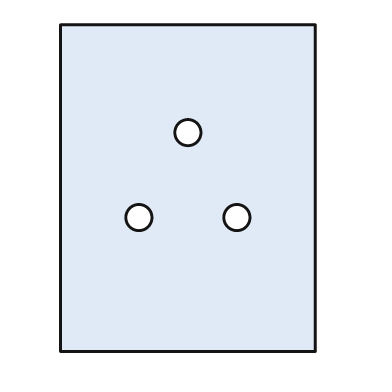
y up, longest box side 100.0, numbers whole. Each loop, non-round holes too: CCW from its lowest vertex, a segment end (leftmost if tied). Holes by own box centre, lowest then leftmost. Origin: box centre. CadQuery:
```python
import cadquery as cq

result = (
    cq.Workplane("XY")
    .moveTo(-39.0, -50.0)
    .lineTo(39.0, -50.0)
    .lineTo(39.0, 50.0)
    .lineTo(-39.0, 50.0)
    .close()
    .moveTo(-15.0, -9.0)
    .circle(4.0)
    .moveTo(15.0, -9.0)
    .circle(4.0)
    .moveTo(0.0, 17.0)
    .circle(4.0)
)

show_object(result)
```